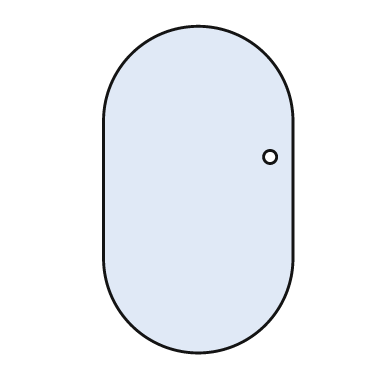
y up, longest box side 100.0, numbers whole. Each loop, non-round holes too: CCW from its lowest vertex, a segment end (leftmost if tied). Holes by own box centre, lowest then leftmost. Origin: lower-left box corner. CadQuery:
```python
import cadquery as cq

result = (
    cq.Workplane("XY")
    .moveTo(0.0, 29.0)
    .threePointArc((29.0, 0.0), (58.0, 29.0))
    .lineTo(58.0, 71.0)
    .threePointArc((29.0, 100.0), (0.0, 71.0))
    .close()
    .moveTo(51.0, 60.0)
    .circle(2.0)
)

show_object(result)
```